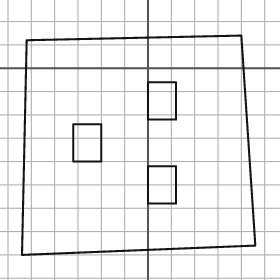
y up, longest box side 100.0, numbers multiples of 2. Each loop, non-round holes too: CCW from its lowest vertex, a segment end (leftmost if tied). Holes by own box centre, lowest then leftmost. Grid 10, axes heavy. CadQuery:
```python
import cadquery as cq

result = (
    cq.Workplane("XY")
    .moveTo(-54.0, -80.0)
    .lineTo(46.0, -76.0)
    .lineTo(40.0, 14.0)
    .lineTo(-52.0, 12.0)
    .close()
    .moveTo(0.0, -58.0)
    .lineTo(12.0, -58.0)
    .lineTo(12.0, -42.0)
    .lineTo(0.0, -42.0)
    .close()
    .moveTo(-32.0, -40.0)
    .lineTo(-20.0, -40.0)
    .lineTo(-20.0, -24.0)
    .lineTo(-32.0, -24.0)
    .close()
    .moveTo(0.0, -22.0)
    .lineTo(12.0, -22.0)
    .lineTo(12.0, -6.0)
    .lineTo(0.0, -6.0)
    .close()
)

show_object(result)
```